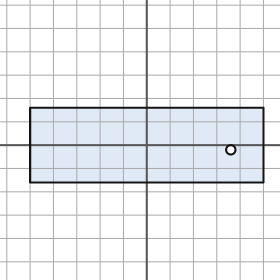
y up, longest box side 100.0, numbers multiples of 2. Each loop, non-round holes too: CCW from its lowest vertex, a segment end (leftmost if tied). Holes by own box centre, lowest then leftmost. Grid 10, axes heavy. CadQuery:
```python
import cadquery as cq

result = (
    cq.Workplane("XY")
    .moveTo(-50.0, -16.0)
    .lineTo(50.0, -16.0)
    .lineTo(50.0, 16.0)
    .lineTo(-50.0, 16.0)
    .close()
    .moveTo(36.0, -2.0)
    .circle(2.0)
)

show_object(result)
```